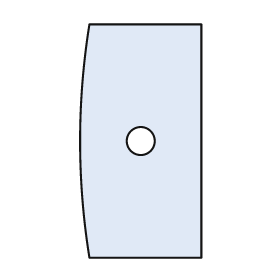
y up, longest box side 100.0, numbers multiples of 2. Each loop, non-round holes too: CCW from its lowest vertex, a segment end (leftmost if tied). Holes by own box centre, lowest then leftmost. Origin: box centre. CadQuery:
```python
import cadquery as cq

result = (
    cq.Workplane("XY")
    .moveTo(-22.0, -50.0)
    .lineTo(26.0, -50.0)
    .lineTo(26.0, 50.0)
    .lineTo(-22.0, 50.0)
    .threePointArc((-26.0, 0.0), (-22.0, -50.0))
    .close()
    .moveTo(0.0, 0.0)
    .circle(6.0)
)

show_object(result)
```